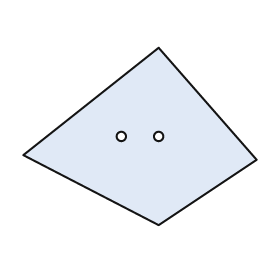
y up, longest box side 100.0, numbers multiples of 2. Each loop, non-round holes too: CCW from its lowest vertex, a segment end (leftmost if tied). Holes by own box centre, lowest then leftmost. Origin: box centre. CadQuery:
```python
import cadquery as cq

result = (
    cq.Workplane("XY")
    .moveTo(8.0, -38.0)
    .lineTo(50.0, -10.0)
    .lineTo(8.0, 38.0)
    .lineTo(-50.0, -8.0)
    .close()
    .moveTo(-8.0, 0.0)
    .circle(2.0)
    .moveTo(8.0, 0.0)
    .circle(2.0)
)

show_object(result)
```